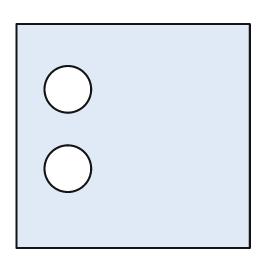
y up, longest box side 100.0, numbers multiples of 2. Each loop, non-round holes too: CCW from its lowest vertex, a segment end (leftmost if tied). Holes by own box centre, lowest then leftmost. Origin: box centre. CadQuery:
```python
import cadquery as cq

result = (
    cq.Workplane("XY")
    .moveTo(-50.0, -48.0)
    .lineTo(50.0, -48.0)
    .lineTo(50.0, 48.0)
    .lineTo(-50.0, 48.0)
    .close()
    .moveTo(-28.0, -14.0)
    .circle(10.0)
    .moveTo(-28.0, 20.0)
    .circle(10.0)
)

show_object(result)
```